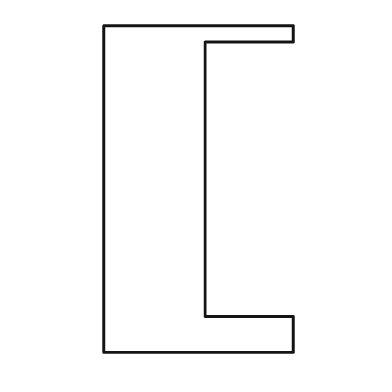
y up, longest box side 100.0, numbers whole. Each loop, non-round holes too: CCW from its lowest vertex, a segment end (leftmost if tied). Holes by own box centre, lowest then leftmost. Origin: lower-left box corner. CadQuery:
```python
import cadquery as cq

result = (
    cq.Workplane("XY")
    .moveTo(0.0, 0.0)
    .lineTo(58.0, 0.0)
    .lineTo(58.0, 11.0)
    .lineTo(31.0, 11.0)
    .lineTo(31.0, 95.0)
    .lineTo(58.0, 95.0)
    .lineTo(58.0, 100.0)
    .lineTo(0.0, 100.0)
    .close()
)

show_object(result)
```